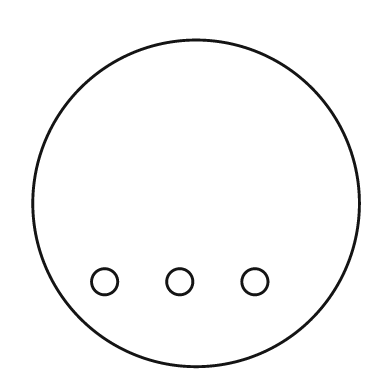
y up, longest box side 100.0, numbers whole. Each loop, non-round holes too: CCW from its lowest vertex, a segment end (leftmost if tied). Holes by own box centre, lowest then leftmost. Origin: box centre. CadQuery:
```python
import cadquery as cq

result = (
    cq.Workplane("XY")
    .moveTo(0.0, 0.0)
    .circle(50.0)
    .moveTo(-28.0, -24.0)
    .circle(4.0)
    .moveTo(-5.0, -24.0)
    .circle(4.0)
    .moveTo(18.0, -24.0)
    .circle(4.0)
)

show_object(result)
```